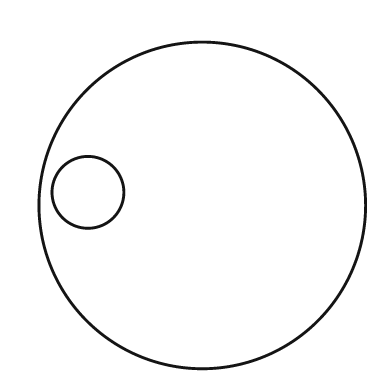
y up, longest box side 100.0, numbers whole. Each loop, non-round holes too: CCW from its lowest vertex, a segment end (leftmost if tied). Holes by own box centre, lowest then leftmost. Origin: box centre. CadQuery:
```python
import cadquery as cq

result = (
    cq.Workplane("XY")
    .moveTo(0.0, 0.0)
    .circle(50.0)
    .moveTo(-35.0, 4.0)
    .circle(11.0)
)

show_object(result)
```